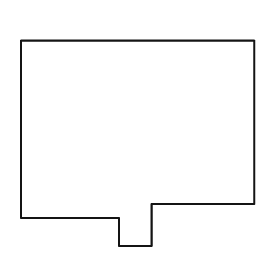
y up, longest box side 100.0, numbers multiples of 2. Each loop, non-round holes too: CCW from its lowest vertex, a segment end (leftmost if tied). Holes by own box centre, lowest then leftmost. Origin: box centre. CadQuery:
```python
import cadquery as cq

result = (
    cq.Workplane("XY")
    .moveTo(-8.0, -44.0)
    .lineTo(6.0, -44.0)
    .lineTo(6.0, -26.0)
    .lineTo(50.0, -26.0)
    .lineTo(50.0, 44.0)
    .lineTo(-50.0, 44.0)
    .lineTo(-50.0, -32.0)
    .lineTo(-8.0, -32.0)
    .close()
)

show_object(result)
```